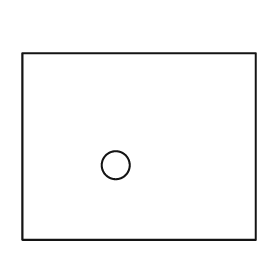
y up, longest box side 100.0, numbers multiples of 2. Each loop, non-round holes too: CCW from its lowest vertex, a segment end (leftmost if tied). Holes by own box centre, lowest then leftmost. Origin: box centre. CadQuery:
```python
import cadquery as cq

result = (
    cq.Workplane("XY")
    .moveTo(-50.0, -40.0)
    .lineTo(50.0, -40.0)
    .lineTo(50.0, 40.0)
    .lineTo(-50.0, 40.0)
    .close()
    .moveTo(-10.0, -8.0)
    .circle(6.0)
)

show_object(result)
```